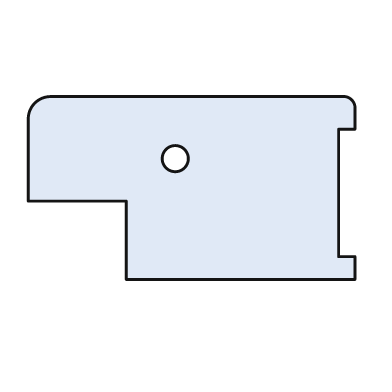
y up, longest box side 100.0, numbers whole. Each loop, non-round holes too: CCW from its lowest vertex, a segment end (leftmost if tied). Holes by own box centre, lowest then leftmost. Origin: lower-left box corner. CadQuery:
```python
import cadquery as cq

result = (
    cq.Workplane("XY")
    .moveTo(30.0, 0.0)
    .lineTo(100.0, 0.0)
    .lineTo(100.0, 7.0)
    .lineTo(95.0, 7.0)
    .lineTo(95.0, 46.0)
    .lineTo(100.0, 46.0)
    .lineTo(100.0, 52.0)
    .threePointArc((99.0, 55.0), (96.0, 56.0))
    .lineTo(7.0, 56.0)
    .threePointArc((2.0, 54.0), (0.0, 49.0))
    .lineTo(0.0, 24.0)
    .lineTo(30.0, 24.0)
    .close()
    .moveTo(45.0, 37.0)
    .circle(4.0)
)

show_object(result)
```